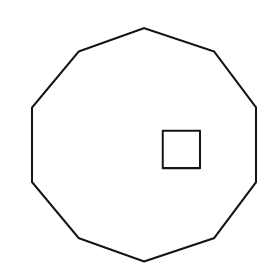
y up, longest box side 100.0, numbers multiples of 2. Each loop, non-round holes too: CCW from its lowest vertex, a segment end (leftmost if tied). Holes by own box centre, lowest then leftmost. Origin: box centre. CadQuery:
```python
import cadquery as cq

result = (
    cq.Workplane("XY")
    .moveTo(0.0, -50.0)
    .lineTo(30.0, -40.0)
    .lineTo(48.0, -16.0)
    .lineTo(48.0, 16.0)
    .lineTo(30.0, 40.0)
    .lineTo(0.0, 50.0)
    .lineTo(-28.0, 40.0)
    .lineTo(-48.0, 16.0)
    .lineTo(-48.0, -16.0)
    .lineTo(-28.0, -40.0)
    .close()
    .moveTo(8.0, -10.0)
    .lineTo(24.0, -10.0)
    .lineTo(24.0, 6.0)
    .lineTo(8.0, 6.0)
    .close()
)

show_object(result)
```